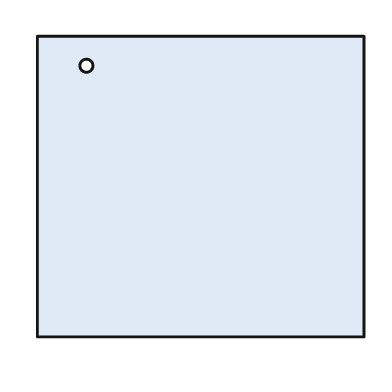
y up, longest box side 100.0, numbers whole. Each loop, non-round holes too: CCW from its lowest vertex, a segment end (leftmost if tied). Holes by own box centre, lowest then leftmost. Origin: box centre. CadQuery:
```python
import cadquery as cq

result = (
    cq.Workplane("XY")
    .moveTo(-50.0, -46.0)
    .lineTo(50.0, -46.0)
    .lineTo(50.0, 46.0)
    .lineTo(-50.0, 46.0)
    .close()
    .moveTo(-35.0, 37.0)
    .circle(2.0)
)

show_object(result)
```